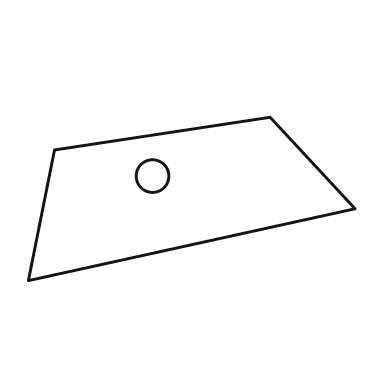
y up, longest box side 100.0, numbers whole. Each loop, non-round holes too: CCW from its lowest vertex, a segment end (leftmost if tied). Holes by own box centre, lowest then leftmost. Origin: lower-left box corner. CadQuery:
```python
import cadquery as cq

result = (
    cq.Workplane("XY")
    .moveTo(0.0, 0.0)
    .lineTo(100.0, 22.0)
    .lineTo(74.0, 50.0)
    .lineTo(8.0, 40.0)
    .close()
    .moveTo(38.0, 32.0)
    .circle(5.0)
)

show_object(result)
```